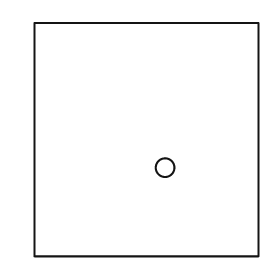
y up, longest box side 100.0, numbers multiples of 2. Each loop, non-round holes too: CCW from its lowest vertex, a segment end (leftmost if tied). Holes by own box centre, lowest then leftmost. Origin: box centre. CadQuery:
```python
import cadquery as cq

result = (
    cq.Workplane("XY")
    .moveTo(-48.0, -50.0)
    .lineTo(48.0, -50.0)
    .lineTo(48.0, 50.0)
    .lineTo(-48.0, 50.0)
    .close()
    .moveTo(8.0, -12.0)
    .circle(4.0)
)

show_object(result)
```